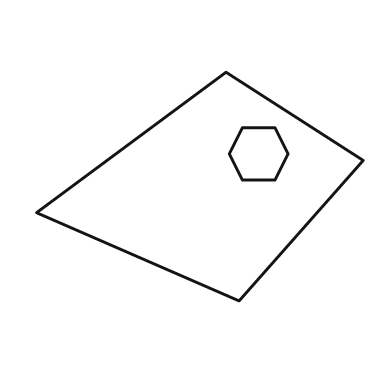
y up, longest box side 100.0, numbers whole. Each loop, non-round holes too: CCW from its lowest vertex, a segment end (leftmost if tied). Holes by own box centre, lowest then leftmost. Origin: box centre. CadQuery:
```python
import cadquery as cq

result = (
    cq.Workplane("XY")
    .moveTo(12.0, -35.0)
    .lineTo(50.0, 8.0)
    .lineTo(8.0, 35.0)
    .lineTo(-50.0, -8.0)
    .close()
    .moveTo(13.0, 2.0)
    .lineTo(23.0, 2.0)
    .lineTo(27.0, 10.0)
    .lineTo(23.0, 18.0)
    .lineTo(13.0, 18.0)
    .lineTo(9.0, 10.0)
    .close()
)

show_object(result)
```